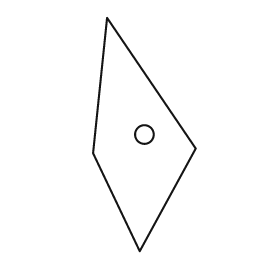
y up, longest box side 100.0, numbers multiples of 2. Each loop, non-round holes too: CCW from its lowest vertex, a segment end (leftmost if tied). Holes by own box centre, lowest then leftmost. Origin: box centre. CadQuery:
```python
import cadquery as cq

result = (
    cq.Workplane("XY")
    .moveTo(-2.0, -50.0)
    .lineTo(22.0, -6.0)
    .lineTo(-16.0, 50.0)
    .lineTo(-22.0, -8.0)
    .close()
    .moveTo(0.0, 0.0)
    .circle(4.0)
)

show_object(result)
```